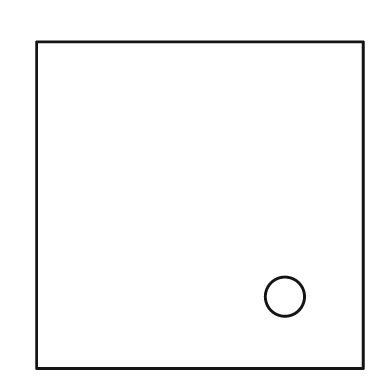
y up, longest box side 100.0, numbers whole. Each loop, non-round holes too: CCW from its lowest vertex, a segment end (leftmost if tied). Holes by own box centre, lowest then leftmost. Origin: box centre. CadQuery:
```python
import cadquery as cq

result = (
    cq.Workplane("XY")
    .moveTo(-50.0, -50.0)
    .lineTo(50.0, -50.0)
    .lineTo(50.0, 50.0)
    .lineTo(-50.0, 50.0)
    .close()
    .moveTo(26.0, -28.0)
    .circle(6.0)
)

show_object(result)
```